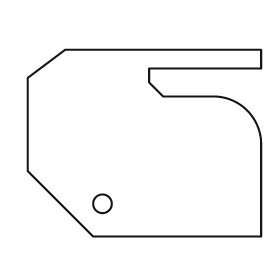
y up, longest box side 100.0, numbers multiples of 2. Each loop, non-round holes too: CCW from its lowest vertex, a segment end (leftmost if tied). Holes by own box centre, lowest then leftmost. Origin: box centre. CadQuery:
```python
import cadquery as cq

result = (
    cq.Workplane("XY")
    .moveTo(-22.0, -40.0)
    .lineTo(50.0, -40.0)
    .lineTo(50.0, 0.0)
    .threePointArc((44.0, 14.0), (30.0, 20.0))
    .lineTo(8.0, 20.0)
    .lineTo(2.0, 26.0)
    .lineTo(2.0, 32.0)
    .lineTo(50.0, 32.0)
    .lineTo(50.0, 40.0)
    .lineTo(-34.0, 40.0)
    .lineTo(-50.0, 28.0)
    .lineTo(-50.0, -12.0)
    .close()
    .moveTo(-18.0, -26.0)
    .circle(4.0)
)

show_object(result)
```